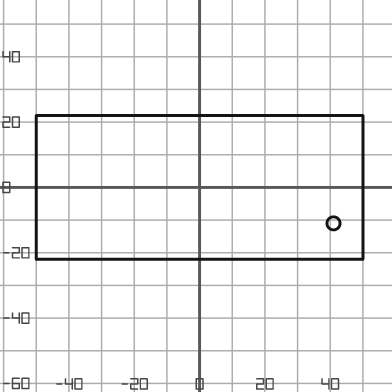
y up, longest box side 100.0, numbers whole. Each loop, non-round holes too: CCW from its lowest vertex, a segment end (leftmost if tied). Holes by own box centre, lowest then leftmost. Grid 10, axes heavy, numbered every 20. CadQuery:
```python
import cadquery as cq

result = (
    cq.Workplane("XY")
    .moveTo(-50.0, -22.0)
    .lineTo(50.0, -22.0)
    .lineTo(50.0, 22.0)
    .lineTo(-50.0, 22.0)
    .close()
    .moveTo(41.0, -11.0)
    .circle(2.0)
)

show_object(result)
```